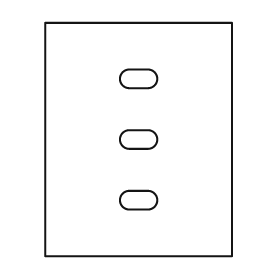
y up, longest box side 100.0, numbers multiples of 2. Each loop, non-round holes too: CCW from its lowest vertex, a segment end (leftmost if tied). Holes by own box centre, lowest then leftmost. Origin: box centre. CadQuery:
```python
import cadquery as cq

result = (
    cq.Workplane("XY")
    .moveTo(-40.0, -50.0)
    .lineTo(40.0, -50.0)
    .lineTo(40.0, 50.0)
    .lineTo(-40.0, 50.0)
    .close()
    .moveTo(-4.0, -30.0)
    .lineTo(4.0, -30.0)
    .threePointArc((8.0, -26.0), (4.0, -22.0))
    .lineTo(-4.0, -22.0)
    .threePointArc((-8.0, -26.0), (-4.0, -30.0))
    .close()
    .moveTo(-4.0, -4.0)
    .lineTo(4.0, -4.0)
    .threePointArc((8.0, 0.0), (4.0, 4.0))
    .lineTo(-4.0, 4.0)
    .threePointArc((-8.0, 0.0), (-4.0, -4.0))
    .close()
    .moveTo(-4.0, 22.0)
    .lineTo(4.0, 22.0)
    .threePointArc((8.0, 26.0), (4.0, 30.0))
    .lineTo(-4.0, 30.0)
    .threePointArc((-8.0, 26.0), (-4.0, 22.0))
    .close()
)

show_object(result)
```